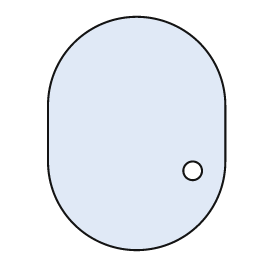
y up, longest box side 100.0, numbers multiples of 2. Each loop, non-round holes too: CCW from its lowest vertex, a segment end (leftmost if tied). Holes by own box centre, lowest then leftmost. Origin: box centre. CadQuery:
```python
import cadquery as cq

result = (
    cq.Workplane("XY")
    .moveTo(-38.0, -12.0)
    .threePointArc((0.0, -50.0), (38.0, -12.0))
    .lineTo(38.0, 12.0)
    .threePointArc((0.0, 50.0), (-38.0, 12.0))
    .close()
    .moveTo(24.0, -16.0)
    .circle(4.0)
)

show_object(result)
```